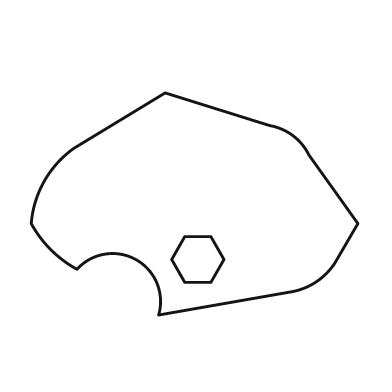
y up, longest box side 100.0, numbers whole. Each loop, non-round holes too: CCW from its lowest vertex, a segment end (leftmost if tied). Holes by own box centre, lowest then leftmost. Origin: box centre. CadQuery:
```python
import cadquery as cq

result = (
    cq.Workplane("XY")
    .moveTo(-11.0, -34.0)
    .lineTo(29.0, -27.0)
    .threePointArc((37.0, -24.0), (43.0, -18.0))
    .lineTo(50.0, -6.0)
    .lineTo(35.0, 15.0)
    .threePointArc((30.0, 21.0), (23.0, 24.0))
    .lineTo(-9.0, 34.0)
    .lineTo(-37.0, 17.0)
    .threePointArc((-46.0, 7.0), (-50.0, -6.0))
    .threePointArc((-44.0, -14.0), (-36.0, -20.0))
    .threePointArc((-18.0, -17.0), (-11.0, -34.0))
    .close()
    .moveTo(-3.0, -24.0)
    .lineTo(5.0, -24.0)
    .lineTo(9.0, -17.0)
    .lineTo(5.0, -10.0)
    .lineTo(-3.0, -10.0)
    .lineTo(-7.0, -17.0)
    .close()
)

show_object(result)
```